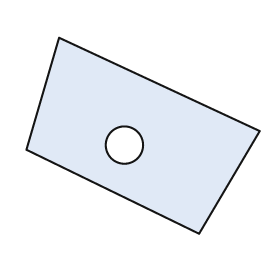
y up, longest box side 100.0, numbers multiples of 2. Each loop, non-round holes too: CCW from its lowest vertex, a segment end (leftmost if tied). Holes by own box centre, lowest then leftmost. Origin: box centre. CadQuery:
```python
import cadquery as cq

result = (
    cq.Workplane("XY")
    .moveTo(24.0, -42.0)
    .lineTo(50.0, 2.0)
    .lineTo(-36.0, 42.0)
    .lineTo(-50.0, -6.0)
    .close()
    .moveTo(-8.0, -4.0)
    .circle(8.0)
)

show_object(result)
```